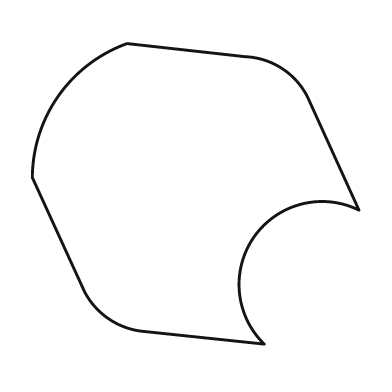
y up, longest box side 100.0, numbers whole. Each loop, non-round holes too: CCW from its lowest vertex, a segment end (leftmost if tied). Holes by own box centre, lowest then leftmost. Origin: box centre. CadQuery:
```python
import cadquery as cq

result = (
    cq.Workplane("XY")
    .moveTo(21.0, -46.0)
    .threePointArc((18.0, -13.0), (50.0, -5.0))
    .lineTo(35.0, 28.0)
    .threePointArc((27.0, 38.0), (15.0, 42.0))
    .lineTo(-21.0, 46.0)
    .threePointArc((-42.0, 30.0), (-50.0, 5.0))
    .lineTo(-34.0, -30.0)
    .threePointArc((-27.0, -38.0), (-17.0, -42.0))
    .close()
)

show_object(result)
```